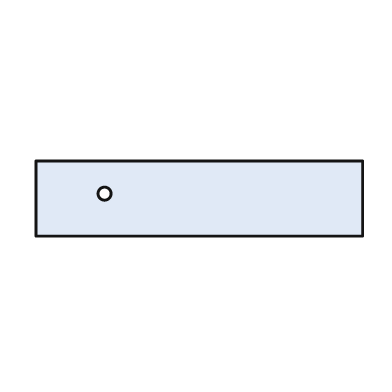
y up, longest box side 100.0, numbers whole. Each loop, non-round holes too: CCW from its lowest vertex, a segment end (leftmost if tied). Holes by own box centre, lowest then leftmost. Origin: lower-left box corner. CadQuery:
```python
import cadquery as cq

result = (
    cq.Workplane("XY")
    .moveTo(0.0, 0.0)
    .lineTo(100.0, 0.0)
    .lineTo(100.0, 23.0)
    .lineTo(0.0, 23.0)
    .close()
    .moveTo(21.0, 13.0)
    .circle(2.0)
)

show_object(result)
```